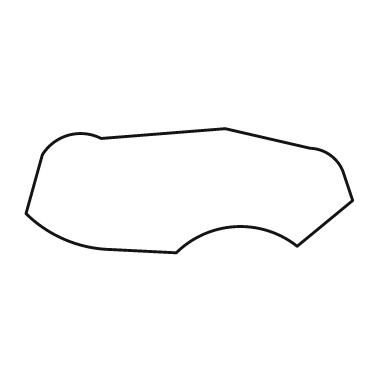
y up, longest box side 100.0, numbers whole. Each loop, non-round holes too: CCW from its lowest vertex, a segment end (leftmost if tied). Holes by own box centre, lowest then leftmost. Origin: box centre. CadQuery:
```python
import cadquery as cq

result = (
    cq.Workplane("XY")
    .moveTo(-4.0, -19.0)
    .threePointArc((14.0, -11.0), (33.0, -17.0))
    .lineTo(50.0, -3.0)
    .lineTo(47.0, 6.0)
    .threePointArc((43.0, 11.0), (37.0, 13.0))
    .lineTo(11.0, 19.0)
    .lineTo(-27.0, 16.0)
    .threePointArc((-37.0, 17.0), (-45.0, 11.0))
    .lineTo(-50.0, -7.0)
    .threePointArc((-38.0, -15.0), (-24.0, -18.0))
    .close()
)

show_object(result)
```